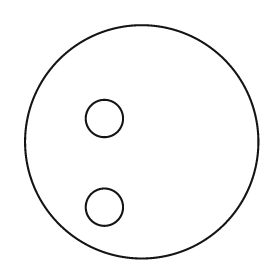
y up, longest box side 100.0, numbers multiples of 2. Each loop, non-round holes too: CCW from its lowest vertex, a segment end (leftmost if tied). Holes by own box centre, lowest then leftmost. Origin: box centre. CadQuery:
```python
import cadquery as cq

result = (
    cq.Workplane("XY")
    .moveTo(0.0, 0.0)
    .circle(50.0)
    .moveTo(-16.0, -28.0)
    .circle(8.0)
    .moveTo(-16.0, 10.0)
    .circle(8.0)
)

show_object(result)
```